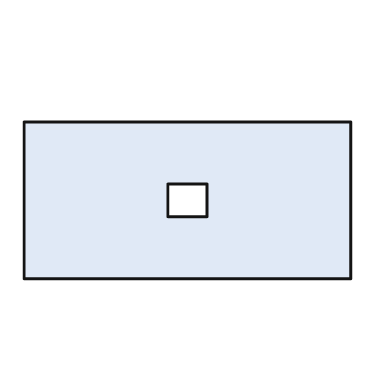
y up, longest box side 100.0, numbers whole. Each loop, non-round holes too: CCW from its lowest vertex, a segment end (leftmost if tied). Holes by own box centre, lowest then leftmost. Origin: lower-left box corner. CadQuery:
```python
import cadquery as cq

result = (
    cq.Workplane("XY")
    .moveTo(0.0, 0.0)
    .lineTo(100.0, 0.0)
    .lineTo(100.0, 48.0)
    .lineTo(0.0, 48.0)
    .close()
    .moveTo(44.0, 19.0)
    .lineTo(56.0, 19.0)
    .lineTo(56.0, 29.0)
    .lineTo(44.0, 29.0)
    .close()
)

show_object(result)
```